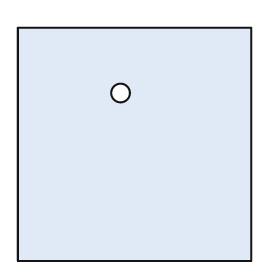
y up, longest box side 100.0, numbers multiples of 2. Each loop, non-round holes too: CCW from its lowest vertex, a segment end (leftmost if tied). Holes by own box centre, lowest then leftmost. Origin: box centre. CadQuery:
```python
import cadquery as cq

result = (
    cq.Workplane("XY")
    .moveTo(-50.0, -50.0)
    .lineTo(50.0, -50.0)
    .lineTo(50.0, 50.0)
    .lineTo(-50.0, 50.0)
    .close()
    .moveTo(-6.0, 22.0)
    .circle(4.0)
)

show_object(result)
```